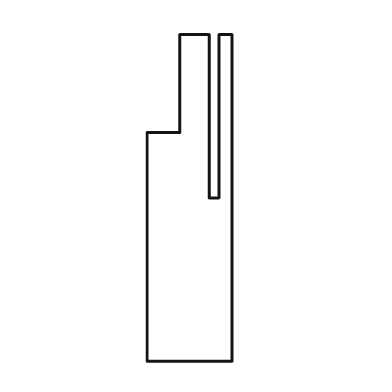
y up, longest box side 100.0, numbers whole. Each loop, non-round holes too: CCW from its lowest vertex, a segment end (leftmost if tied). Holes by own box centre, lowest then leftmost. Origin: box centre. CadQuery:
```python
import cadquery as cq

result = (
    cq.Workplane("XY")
    .moveTo(-13.0, -50.0)
    .lineTo(13.0, -50.0)
    .lineTo(13.0, 50.0)
    .lineTo(9.0, 50.0)
    .lineTo(9.0, 0.0)
    .lineTo(6.0, 0.0)
    .lineTo(6.0, 50.0)
    .lineTo(-3.0, 50.0)
    .lineTo(-3.0, 20.0)
    .lineTo(-13.0, 20.0)
    .close()
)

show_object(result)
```